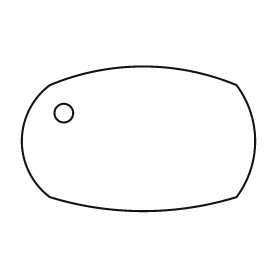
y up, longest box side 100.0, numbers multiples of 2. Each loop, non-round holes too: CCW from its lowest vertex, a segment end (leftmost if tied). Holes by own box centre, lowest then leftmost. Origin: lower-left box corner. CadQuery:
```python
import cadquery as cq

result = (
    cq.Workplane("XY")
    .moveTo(12.0, 6.0)
    .threePointArc((52.0, 0.0), (92.0, 6.0))
    .threePointArc((100.0, 30.0), (92.0, 54.0))
    .threePointArc((52.0, 62.0), (12.0, 54.0))
    .threePointArc((0.0, 30.0), (12.0, 6.0))
    .close()
    .moveTo(18.0, 42.0)
    .circle(4.0)
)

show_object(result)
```